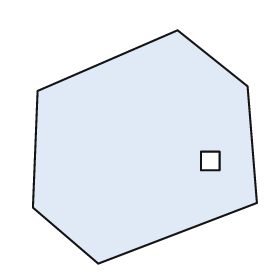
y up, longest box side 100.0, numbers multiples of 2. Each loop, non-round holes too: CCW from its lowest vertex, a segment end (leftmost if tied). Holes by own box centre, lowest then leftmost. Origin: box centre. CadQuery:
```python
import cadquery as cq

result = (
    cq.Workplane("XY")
    .moveTo(-20.0, -50.0)
    .lineTo(48.0, -24.0)
    .lineTo(44.0, 26.0)
    .lineTo(14.0, 50.0)
    .lineTo(-46.0, 24.0)
    .lineTo(-48.0, -26.0)
    .close()
    .moveTo(24.0, -10.0)
    .lineTo(32.0, -10.0)
    .lineTo(32.0, -2.0)
    .lineTo(24.0, -2.0)
    .close()
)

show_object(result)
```